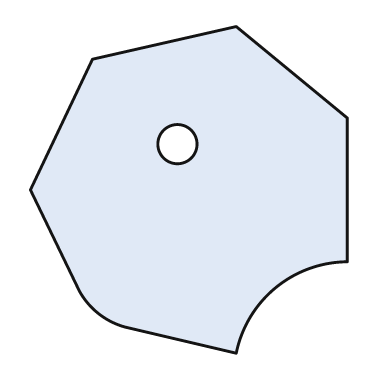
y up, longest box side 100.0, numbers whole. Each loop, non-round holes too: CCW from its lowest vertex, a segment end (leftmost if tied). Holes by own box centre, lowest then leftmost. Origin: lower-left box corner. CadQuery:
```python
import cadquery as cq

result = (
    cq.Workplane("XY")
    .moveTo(63.0, 0.0)
    .threePointArc((75.0, 20.0), (97.0, 28.0))
    .lineTo(97.0, 72.0)
    .lineTo(63.0, 100.0)
    .lineTo(19.0, 90.0)
    .lineTo(0.0, 50.0)
    .lineTo(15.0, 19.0)
    .threePointArc((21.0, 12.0), (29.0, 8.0))
    .close()
    .moveTo(45.0, 64.0)
    .circle(6.0)
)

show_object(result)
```